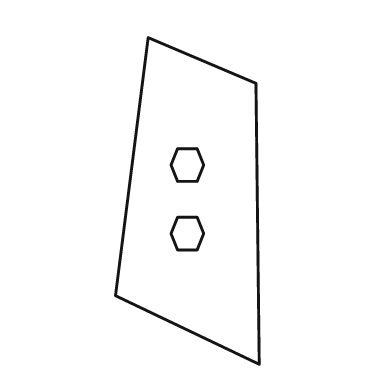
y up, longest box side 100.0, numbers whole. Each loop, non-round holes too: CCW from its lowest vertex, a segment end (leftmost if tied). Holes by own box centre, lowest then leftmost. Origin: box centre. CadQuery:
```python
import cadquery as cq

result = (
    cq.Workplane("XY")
    .moveTo(22.0, -50.0)
    .lineTo(21.0, 36.0)
    .lineTo(-12.0, 50.0)
    .lineTo(-22.0, -29.0)
    .close()
    .moveTo(-3.0, -15.0)
    .lineTo(3.0, -15.0)
    .lineTo(5.0, -10.0)
    .lineTo(3.0, -5.0)
    .lineTo(-3.0, -5.0)
    .lineTo(-5.0, -10.0)
    .close()
    .moveTo(-3.0, 6.0)
    .lineTo(3.0, 6.0)
    .lineTo(5.0, 11.0)
    .lineTo(3.0, 16.0)
    .lineTo(-3.0, 16.0)
    .lineTo(-5.0, 11.0)
    .close()
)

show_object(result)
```